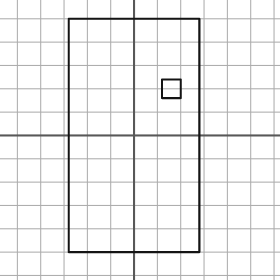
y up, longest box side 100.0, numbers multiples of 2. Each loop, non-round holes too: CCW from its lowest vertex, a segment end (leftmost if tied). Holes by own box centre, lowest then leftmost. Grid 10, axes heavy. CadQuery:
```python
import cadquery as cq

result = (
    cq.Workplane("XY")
    .moveTo(-28.0, -50.0)
    .lineTo(28.0, -50.0)
    .lineTo(28.0, 50.0)
    .lineTo(-28.0, 50.0)
    .close()
    .moveTo(12.0, 16.0)
    .lineTo(20.0, 16.0)
    .lineTo(20.0, 24.0)
    .lineTo(12.0, 24.0)
    .close()
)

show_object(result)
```